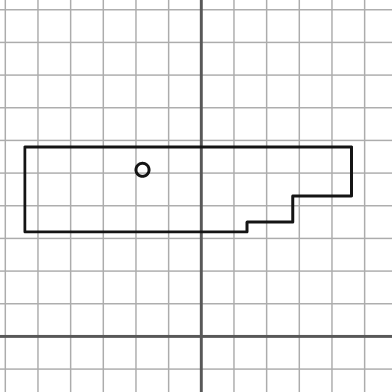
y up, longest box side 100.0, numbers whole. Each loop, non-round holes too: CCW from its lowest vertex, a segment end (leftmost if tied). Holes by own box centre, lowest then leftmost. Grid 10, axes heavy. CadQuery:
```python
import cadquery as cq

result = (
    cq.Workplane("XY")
    .moveTo(-54.0, 32.0)
    .lineTo(14.0, 32.0)
    .lineTo(14.0, 35.0)
    .lineTo(28.0, 35.0)
    .lineTo(28.0, 43.0)
    .lineTo(46.0, 43.0)
    .lineTo(46.0, 58.0)
    .lineTo(-54.0, 58.0)
    .close()
    .moveTo(-18.0, 51.0)
    .circle(2.0)
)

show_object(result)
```